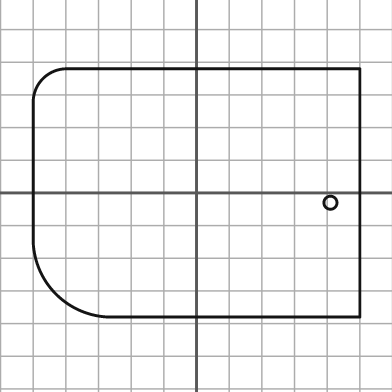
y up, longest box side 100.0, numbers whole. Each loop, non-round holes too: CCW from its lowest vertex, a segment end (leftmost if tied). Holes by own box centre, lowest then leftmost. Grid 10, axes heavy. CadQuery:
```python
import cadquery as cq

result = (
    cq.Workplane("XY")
    .moveTo(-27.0, -38.0)
    .lineTo(50.0, -38.0)
    .lineTo(50.0, 38.0)
    .lineTo(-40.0, 38.0)
    .threePointArc((-47.0, 35.0), (-50.0, 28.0))
    .lineTo(-50.0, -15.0)
    .threePointArc((-43.0, -31.0), (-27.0, -38.0))
    .close()
    .moveTo(41.0, -3.0)
    .circle(2.0)
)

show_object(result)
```